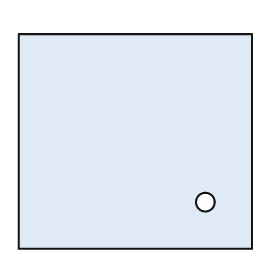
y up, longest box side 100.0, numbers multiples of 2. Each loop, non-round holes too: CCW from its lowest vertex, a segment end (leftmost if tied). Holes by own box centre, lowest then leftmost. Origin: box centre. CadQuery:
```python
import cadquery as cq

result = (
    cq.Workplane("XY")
    .moveTo(-50.0, -46.0)
    .lineTo(50.0, -46.0)
    .lineTo(50.0, 46.0)
    .lineTo(-50.0, 46.0)
    .close()
    .moveTo(30.0, -26.0)
    .circle(4.0)
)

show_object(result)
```